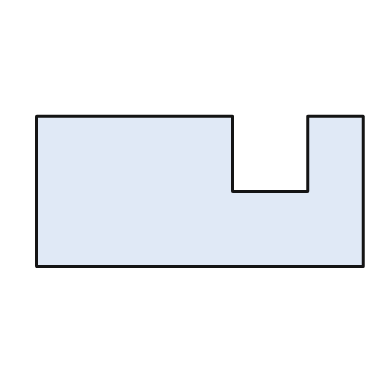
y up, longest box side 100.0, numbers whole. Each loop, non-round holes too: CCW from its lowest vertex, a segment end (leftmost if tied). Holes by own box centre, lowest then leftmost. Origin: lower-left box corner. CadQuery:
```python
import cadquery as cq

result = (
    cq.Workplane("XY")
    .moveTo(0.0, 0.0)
    .lineTo(100.0, 0.0)
    .lineTo(100.0, 46.0)
    .lineTo(83.0, 46.0)
    .lineTo(83.0, 23.0)
    .lineTo(60.0, 23.0)
    .lineTo(60.0, 46.0)
    .lineTo(0.0, 46.0)
    .close()
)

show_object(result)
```